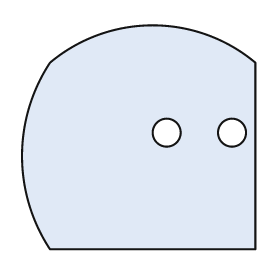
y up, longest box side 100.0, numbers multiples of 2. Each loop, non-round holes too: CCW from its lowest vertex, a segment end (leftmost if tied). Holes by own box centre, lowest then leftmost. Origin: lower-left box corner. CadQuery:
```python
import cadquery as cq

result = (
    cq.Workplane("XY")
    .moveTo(12.0, 0.0)
    .lineTo(100.0, 0.0)
    .lineTo(100.0, 80.0)
    .threePointArc((56.0, 96.0), (12.0, 80.0))
    .threePointArc((0.0, 40.0), (12.0, 0.0))
    .close()
    .moveTo(62.0, 50.0)
    .circle(6.0)
    .moveTo(90.0, 50.0)
    .circle(6.0)
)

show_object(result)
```